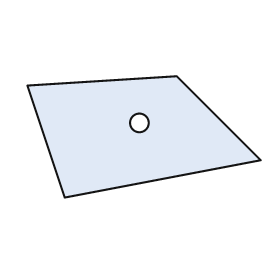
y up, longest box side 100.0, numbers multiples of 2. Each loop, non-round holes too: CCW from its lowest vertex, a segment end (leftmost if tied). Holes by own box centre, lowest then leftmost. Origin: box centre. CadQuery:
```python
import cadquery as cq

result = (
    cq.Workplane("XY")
    .moveTo(-34.0, -26.0)
    .lineTo(50.0, -10.0)
    .lineTo(14.0, 26.0)
    .lineTo(-50.0, 22.0)
    .close()
    .moveTo(-2.0, 6.0)
    .circle(4.0)
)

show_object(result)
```